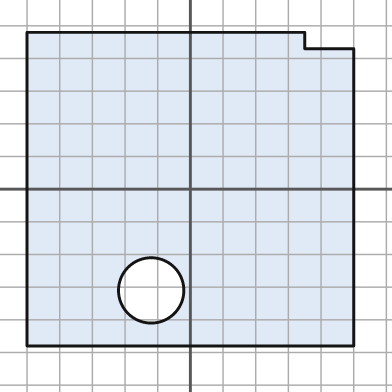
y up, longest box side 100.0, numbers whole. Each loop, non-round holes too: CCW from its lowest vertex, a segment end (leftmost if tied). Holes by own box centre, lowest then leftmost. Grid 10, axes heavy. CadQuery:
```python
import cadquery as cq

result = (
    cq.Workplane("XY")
    .moveTo(-50.0, -48.0)
    .lineTo(50.0, -48.0)
    .lineTo(50.0, 43.0)
    .lineTo(35.0, 43.0)
    .lineTo(35.0, 48.0)
    .lineTo(-50.0, 48.0)
    .close()
    .moveTo(-12.0, -31.0)
    .circle(10.0)
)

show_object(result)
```